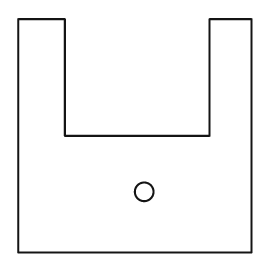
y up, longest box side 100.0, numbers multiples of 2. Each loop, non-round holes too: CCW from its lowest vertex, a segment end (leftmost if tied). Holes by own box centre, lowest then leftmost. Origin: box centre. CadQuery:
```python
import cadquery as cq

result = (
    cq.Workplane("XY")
    .moveTo(-50.0, -50.0)
    .lineTo(50.0, -50.0)
    .lineTo(50.0, 50.0)
    .lineTo(32.0, 50.0)
    .lineTo(32.0, 0.0)
    .lineTo(-30.0, 0.0)
    .lineTo(-30.0, 50.0)
    .lineTo(-50.0, 50.0)
    .close()
    .moveTo(4.0, -24.0)
    .circle(4.0)
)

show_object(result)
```